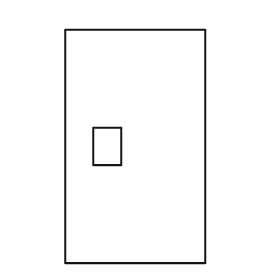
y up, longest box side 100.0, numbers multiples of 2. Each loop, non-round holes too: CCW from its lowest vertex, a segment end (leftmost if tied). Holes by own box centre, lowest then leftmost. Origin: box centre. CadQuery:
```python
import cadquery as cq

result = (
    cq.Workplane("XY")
    .moveTo(-30.0, -50.0)
    .lineTo(30.0, -50.0)
    .lineTo(30.0, 50.0)
    .lineTo(-30.0, 50.0)
    .close()
    .moveTo(-18.0, -8.0)
    .lineTo(-6.0, -8.0)
    .lineTo(-6.0, 8.0)
    .lineTo(-18.0, 8.0)
    .close()
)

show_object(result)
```